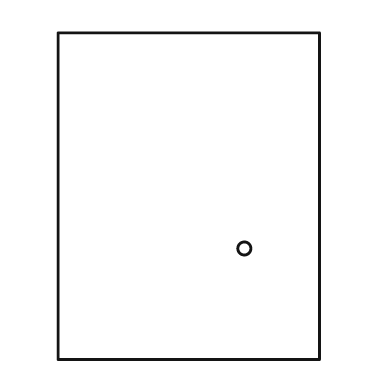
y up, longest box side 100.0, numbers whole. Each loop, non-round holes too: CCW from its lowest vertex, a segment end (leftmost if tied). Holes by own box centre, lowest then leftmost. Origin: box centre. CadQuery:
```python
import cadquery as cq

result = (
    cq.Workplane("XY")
    .moveTo(-40.0, -50.0)
    .lineTo(40.0, -50.0)
    .lineTo(40.0, 50.0)
    .lineTo(-40.0, 50.0)
    .close()
    .moveTo(17.0, -16.0)
    .circle(2.0)
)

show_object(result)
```